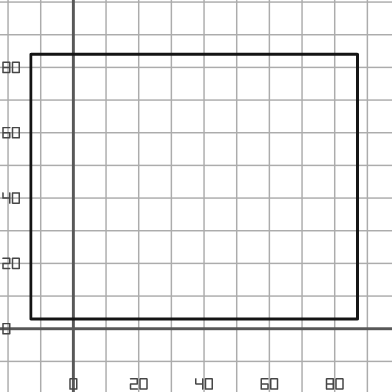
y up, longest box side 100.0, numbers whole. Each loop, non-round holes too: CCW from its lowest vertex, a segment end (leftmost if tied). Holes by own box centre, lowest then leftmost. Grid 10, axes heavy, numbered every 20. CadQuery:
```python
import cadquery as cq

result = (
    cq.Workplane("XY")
    .moveTo(-13.0, 3.0)
    .lineTo(87.0, 3.0)
    .lineTo(87.0, 84.0)
    .lineTo(-13.0, 84.0)
    .close()
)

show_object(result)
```